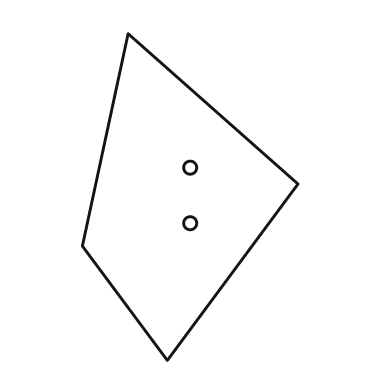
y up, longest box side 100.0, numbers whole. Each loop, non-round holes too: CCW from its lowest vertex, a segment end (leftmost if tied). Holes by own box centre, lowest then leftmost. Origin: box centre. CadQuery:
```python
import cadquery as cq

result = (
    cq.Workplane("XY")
    .moveTo(-7.0, -50.0)
    .lineTo(33.0, 4.0)
    .lineTo(-19.0, 50.0)
    .lineTo(-33.0, -15.0)
    .close()
    .moveTo(0.0, -8.0)
    .circle(2.0)
    .moveTo(0.0, 9.0)
    .circle(2.0)
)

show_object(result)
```